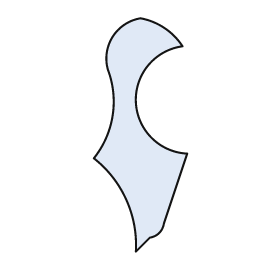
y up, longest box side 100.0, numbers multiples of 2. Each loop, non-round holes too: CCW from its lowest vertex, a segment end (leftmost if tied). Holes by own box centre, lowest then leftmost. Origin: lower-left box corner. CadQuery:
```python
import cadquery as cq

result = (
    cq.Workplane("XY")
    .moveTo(18.0, 0.0)
    .lineTo(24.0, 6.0)
    .threePointArc((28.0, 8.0), (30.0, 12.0))
    .lineTo(40.0, 42.0)
    .threePointArc((18.0, 64.0), (38.0, 88.0))
    .threePointArc((30.0, 96.0), (20.0, 100.0))
    .threePointArc((8.0, 92.0), (6.0, 78.0))
    .threePointArc((8.0, 58.0), (0.0, 40.0))
    .threePointArc((14.0, 22.0), (18.0, 0.0))
    .close()
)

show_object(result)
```